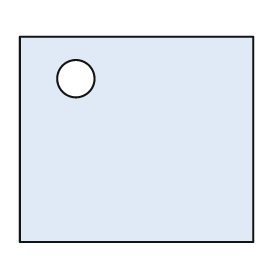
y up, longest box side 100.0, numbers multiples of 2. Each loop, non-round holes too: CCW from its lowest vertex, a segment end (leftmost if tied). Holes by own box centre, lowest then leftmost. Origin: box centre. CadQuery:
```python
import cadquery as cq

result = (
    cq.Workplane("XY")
    .moveTo(-50.0, -44.0)
    .lineTo(50.0, -44.0)
    .lineTo(50.0, 44.0)
    .lineTo(-50.0, 44.0)
    .close()
    .moveTo(-26.0, 26.0)
    .circle(8.0)
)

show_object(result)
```